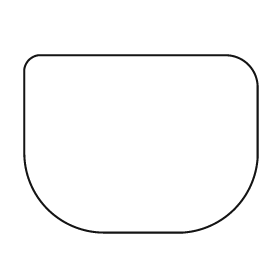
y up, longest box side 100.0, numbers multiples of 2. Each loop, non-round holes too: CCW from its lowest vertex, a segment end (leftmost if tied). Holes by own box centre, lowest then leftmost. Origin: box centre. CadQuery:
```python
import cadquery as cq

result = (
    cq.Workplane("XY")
    .moveTo(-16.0, -38.0)
    .lineTo(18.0, -38.0)
    .threePointArc((40.0, -28.0), (50.0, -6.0))
    .lineTo(50.0, 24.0)
    .threePointArc((46.0, 34.0), (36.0, 38.0))
    .lineTo(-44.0, 38.0)
    .threePointArc((-48.0, 36.0), (-50.0, 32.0))
    .lineTo(-50.0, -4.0)
    .threePointArc((-40.0, -28.0), (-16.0, -38.0))
    .close()
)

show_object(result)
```